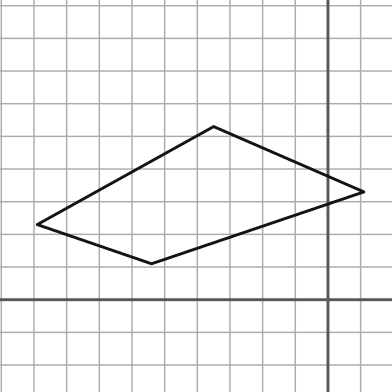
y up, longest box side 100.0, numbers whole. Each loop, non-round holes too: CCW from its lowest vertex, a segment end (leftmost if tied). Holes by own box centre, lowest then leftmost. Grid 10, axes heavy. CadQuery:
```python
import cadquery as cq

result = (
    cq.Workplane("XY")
    .moveTo(-54.0, 11.0)
    .lineTo(11.0, 33.0)
    .lineTo(-35.0, 53.0)
    .lineTo(-89.0, 23.0)
    .close()
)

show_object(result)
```